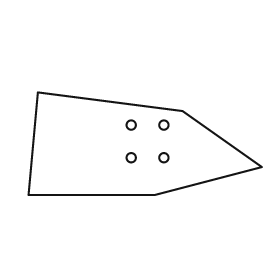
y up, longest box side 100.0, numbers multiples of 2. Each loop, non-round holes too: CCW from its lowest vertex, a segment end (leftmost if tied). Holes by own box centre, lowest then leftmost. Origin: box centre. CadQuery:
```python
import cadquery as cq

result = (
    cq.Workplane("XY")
    .moveTo(-50.0, -22.0)
    .lineTo(4.0, -22.0)
    .lineTo(50.0, -10.0)
    .lineTo(16.0, 14.0)
    .lineTo(-46.0, 22.0)
    .close()
    .moveTo(-6.0, -6.0)
    .circle(2.0)
    .moveTo(8.0, -6.0)
    .circle(2.0)
    .moveTo(-6.0, 8.0)
    .circle(2.0)
    .moveTo(8.0, 8.0)
    .circle(2.0)
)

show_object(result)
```